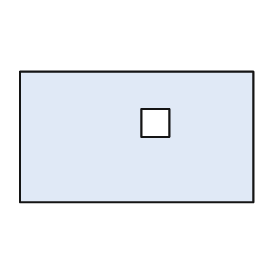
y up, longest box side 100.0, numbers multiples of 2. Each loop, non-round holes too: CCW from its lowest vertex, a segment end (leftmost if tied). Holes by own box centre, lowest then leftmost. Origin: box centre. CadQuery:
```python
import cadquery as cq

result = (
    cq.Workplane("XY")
    .moveTo(-50.0, -28.0)
    .lineTo(50.0, -28.0)
    .lineTo(50.0, 28.0)
    .lineTo(-50.0, 28.0)
    .close()
    .moveTo(2.0, 0.0)
    .lineTo(14.0, 0.0)
    .lineTo(14.0, 12.0)
    .lineTo(2.0, 12.0)
    .close()
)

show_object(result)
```